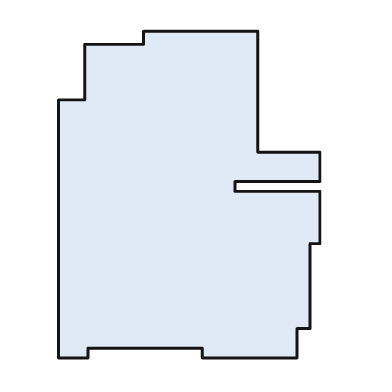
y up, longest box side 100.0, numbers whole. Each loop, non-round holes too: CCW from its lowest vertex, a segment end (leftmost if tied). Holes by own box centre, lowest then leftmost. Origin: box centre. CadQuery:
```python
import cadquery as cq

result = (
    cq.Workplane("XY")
    .moveTo(-40.0, -50.0)
    .lineTo(-31.0, -50.0)
    .lineTo(-31.0, -47.0)
    .lineTo(4.0, -47.0)
    .lineTo(4.0, -50.0)
    .lineTo(33.0, -50.0)
    .lineTo(33.0, -41.0)
    .lineTo(37.0, -41.0)
    .lineTo(37.0, -15.0)
    .lineTo(40.0, -15.0)
    .lineTo(40.0, 1.0)
    .lineTo(14.0, 1.0)
    .lineTo(14.0, 4.0)
    .lineTo(40.0, 4.0)
    .lineTo(40.0, 13.0)
    .lineTo(21.0, 13.0)
    .lineTo(21.0, 50.0)
    .lineTo(-14.0, 50.0)
    .lineTo(-14.0, 46.0)
    .lineTo(-32.0, 46.0)
    .lineTo(-32.0, 29.0)
    .lineTo(-40.0, 29.0)
    .close()
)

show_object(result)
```